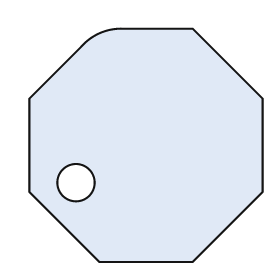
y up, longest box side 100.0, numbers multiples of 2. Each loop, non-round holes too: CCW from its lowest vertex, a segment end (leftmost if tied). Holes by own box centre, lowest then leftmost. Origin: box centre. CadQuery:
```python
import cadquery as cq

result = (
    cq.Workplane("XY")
    .moveTo(-20.0, -50.0)
    .lineTo(20.0, -50.0)
    .lineTo(50.0, -20.0)
    .lineTo(50.0, 20.0)
    .lineTo(20.0, 50.0)
    .lineTo(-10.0, 50.0)
    .threePointArc((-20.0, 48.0), (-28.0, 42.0))
    .lineTo(-50.0, 20.0)
    .lineTo(-50.0, -20.0)
    .close()
    .moveTo(-30.0, -16.0)
    .circle(8.0)
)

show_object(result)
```